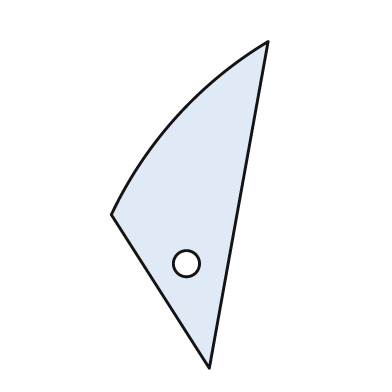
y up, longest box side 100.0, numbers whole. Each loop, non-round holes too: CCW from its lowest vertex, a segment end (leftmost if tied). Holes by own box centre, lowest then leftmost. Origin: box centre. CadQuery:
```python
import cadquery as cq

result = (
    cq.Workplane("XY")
    .moveTo(6.0, -50.0)
    .lineTo(24.0, 50.0)
    .threePointArc((-4.0, 27.0), (-24.0, -3.0))
    .close()
    .moveTo(-1.0, -18.0)
    .circle(4.0)
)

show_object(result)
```